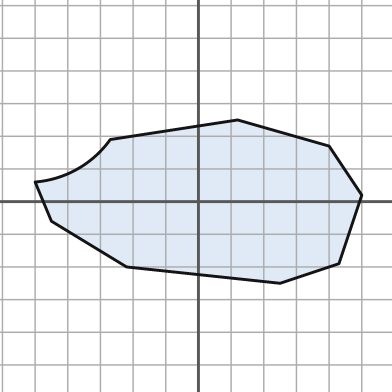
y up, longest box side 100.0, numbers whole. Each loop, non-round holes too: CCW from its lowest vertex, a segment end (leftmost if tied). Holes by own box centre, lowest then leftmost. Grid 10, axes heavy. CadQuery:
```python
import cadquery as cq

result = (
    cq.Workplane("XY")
    .moveTo(25.0, -25.0)
    .lineTo(43.0, -19.0)
    .lineTo(50.0, 2.0)
    .lineTo(40.0, 17.0)
    .lineTo(12.0, 25.0)
    .lineTo(-27.0, 19.0)
    .threePointArc((-37.0, 10.0), (-50.0, 6.0))
    .lineTo(-45.0, -6.0)
    .lineTo(-22.0, -20.0)
    .close()
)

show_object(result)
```